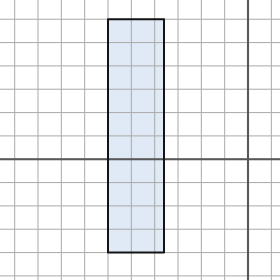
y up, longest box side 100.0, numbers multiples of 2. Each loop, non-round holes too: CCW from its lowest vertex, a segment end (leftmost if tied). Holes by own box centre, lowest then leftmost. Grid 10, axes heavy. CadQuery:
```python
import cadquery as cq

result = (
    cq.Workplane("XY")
    .moveTo(-60.0, -40.0)
    .lineTo(-36.0, -40.0)
    .lineTo(-36.0, 60.0)
    .lineTo(-60.0, 60.0)
    .close()
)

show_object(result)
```